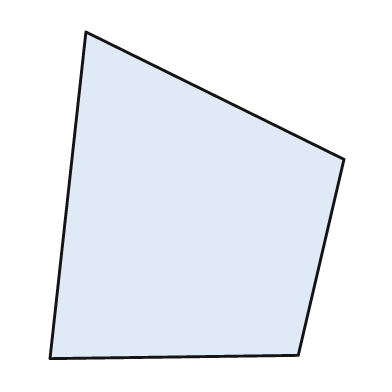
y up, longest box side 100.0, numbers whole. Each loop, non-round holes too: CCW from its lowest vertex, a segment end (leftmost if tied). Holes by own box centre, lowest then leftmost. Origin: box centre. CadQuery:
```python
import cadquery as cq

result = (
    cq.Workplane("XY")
    .moveTo(-45.0, -50.0)
    .lineTo(31.0, -49.0)
    .lineTo(45.0, 11.0)
    .lineTo(-34.0, 50.0)
    .close()
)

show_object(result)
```